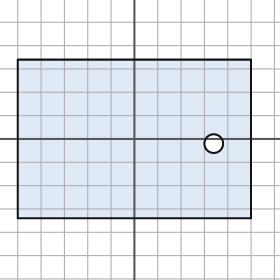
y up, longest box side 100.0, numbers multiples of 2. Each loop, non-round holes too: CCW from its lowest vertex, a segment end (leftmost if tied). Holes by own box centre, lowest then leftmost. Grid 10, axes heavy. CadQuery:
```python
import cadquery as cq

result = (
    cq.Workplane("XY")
    .moveTo(-50.0, -34.0)
    .lineTo(50.0, -34.0)
    .lineTo(50.0, 34.0)
    .lineTo(-50.0, 34.0)
    .close()
    .moveTo(34.0, -2.0)
    .circle(4.0)
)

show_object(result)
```